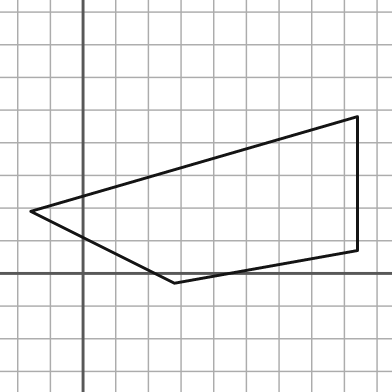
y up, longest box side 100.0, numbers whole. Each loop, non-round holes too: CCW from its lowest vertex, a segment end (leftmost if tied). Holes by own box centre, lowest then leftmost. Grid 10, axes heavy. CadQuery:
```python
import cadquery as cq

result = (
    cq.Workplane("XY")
    .moveTo(28.0, -3.0)
    .lineTo(84.0, 7.0)
    .lineTo(84.0, 48.0)
    .lineTo(-16.0, 19.0)
    .close()
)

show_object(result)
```